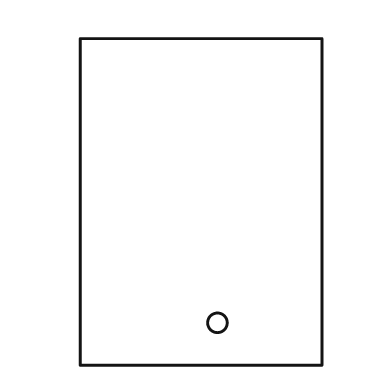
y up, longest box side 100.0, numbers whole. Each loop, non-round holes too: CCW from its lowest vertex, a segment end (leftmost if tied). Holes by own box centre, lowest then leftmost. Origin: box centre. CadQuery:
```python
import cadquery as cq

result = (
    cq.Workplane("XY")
    .moveTo(-37.0, -50.0)
    .lineTo(37.0, -50.0)
    .lineTo(37.0, 50.0)
    .lineTo(-37.0, 50.0)
    .close()
    .moveTo(5.0, -37.0)
    .circle(3.0)
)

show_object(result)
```